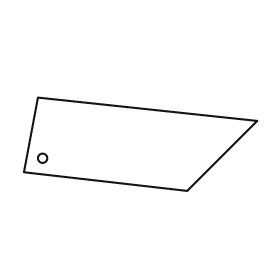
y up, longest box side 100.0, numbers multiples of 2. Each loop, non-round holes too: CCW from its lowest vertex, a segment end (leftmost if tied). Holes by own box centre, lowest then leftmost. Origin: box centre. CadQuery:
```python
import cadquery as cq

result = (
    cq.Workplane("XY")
    .moveTo(20.0, -20.0)
    .lineTo(50.0, 10.0)
    .lineTo(-44.0, 20.0)
    .lineTo(-50.0, -12.0)
    .close()
    .moveTo(-42.0, -6.0)
    .circle(2.0)
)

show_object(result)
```